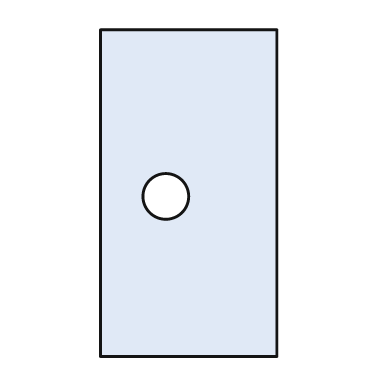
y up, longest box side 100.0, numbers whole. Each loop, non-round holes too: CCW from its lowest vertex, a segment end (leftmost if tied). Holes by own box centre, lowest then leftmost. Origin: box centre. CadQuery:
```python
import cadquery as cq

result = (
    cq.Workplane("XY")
    .moveTo(-27.0, -50.0)
    .lineTo(27.0, -50.0)
    .lineTo(27.0, 50.0)
    .lineTo(-27.0, 50.0)
    .close()
    .moveTo(-7.0, -1.0)
    .circle(7.0)
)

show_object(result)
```